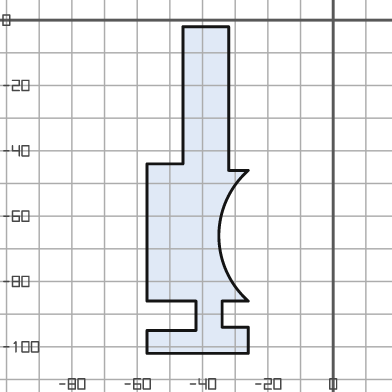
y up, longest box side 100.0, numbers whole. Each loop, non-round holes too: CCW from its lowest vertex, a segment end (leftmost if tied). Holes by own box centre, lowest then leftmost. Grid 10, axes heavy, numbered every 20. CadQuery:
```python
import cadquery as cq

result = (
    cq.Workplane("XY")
    .moveTo(-57.0, -102.0)
    .lineTo(-26.0, -102.0)
    .lineTo(-26.0, -94.0)
    .lineTo(-34.0, -94.0)
    .lineTo(-34.0, -86.0)
    .lineTo(-26.0, -86.0)
    .threePointArc((-35.0, -66.0), (-26.0, -46.0))
    .lineTo(-32.0, -46.0)
    .lineTo(-32.0, -2.0)
    .lineTo(-46.0, -2.0)
    .lineTo(-46.0, -44.0)
    .lineTo(-57.0, -44.0)
    .lineTo(-57.0, -86.0)
    .lineTo(-42.0, -86.0)
    .lineTo(-42.0, -95.0)
    .lineTo(-57.0, -95.0)
    .close()
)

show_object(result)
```